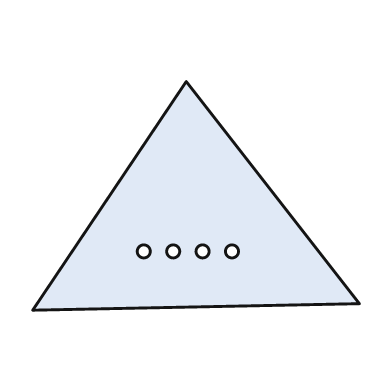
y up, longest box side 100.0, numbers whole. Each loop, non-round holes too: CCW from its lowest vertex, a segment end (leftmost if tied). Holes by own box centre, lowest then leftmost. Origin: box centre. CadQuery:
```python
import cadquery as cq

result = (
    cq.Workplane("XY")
    .moveTo(-50.0, -35.0)
    .lineTo(50.0, -33.0)
    .lineTo(-3.0, 35.0)
    .close()
    .moveTo(-16.0, -17.0)
    .circle(2.0)
    .moveTo(-7.0, -17.0)
    .circle(2.0)
    .moveTo(2.0, -17.0)
    .circle(2.0)
    .moveTo(11.0, -17.0)
    .circle(2.0)
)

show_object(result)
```